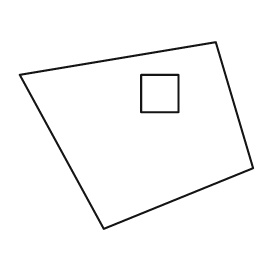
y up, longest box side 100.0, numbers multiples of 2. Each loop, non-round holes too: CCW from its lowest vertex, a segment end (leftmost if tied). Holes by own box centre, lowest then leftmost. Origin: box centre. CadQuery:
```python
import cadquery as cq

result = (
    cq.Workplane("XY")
    .moveTo(-14.0, -40.0)
    .lineTo(50.0, -14.0)
    .lineTo(34.0, 40.0)
    .lineTo(-50.0, 26.0)
    .close()
    .moveTo(2.0, 10.0)
    .lineTo(18.0, 10.0)
    .lineTo(18.0, 26.0)
    .lineTo(2.0, 26.0)
    .close()
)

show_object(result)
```